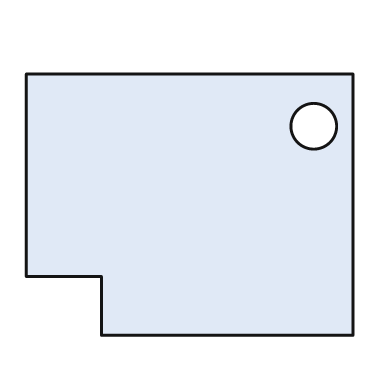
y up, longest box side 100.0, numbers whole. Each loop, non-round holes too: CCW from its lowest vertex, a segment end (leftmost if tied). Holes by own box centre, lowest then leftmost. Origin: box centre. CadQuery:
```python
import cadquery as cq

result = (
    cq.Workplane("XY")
    .moveTo(-27.0, -40.0)
    .lineTo(50.0, -40.0)
    .lineTo(50.0, 40.0)
    .lineTo(-50.0, 40.0)
    .lineTo(-50.0, -22.0)
    .lineTo(-27.0, -22.0)
    .close()
    .moveTo(38.0, 24.0)
    .circle(7.0)
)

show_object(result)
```